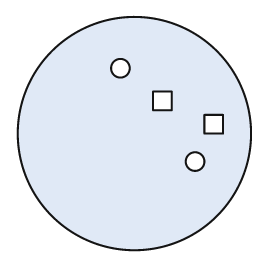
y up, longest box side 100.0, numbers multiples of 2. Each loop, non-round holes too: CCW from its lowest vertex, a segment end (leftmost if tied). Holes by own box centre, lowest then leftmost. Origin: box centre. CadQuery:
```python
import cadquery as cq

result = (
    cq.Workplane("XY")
    .moveTo(0.0, 0.0)
    .circle(50.0)
    .moveTo(26.0, -12.0)
    .circle(4.0)
    .moveTo(30.0, 0.0)
    .lineTo(38.0, 0.0)
    .lineTo(38.0, 8.0)
    .lineTo(30.0, 8.0)
    .close()
    .moveTo(8.0, 10.0)
    .lineTo(16.0, 10.0)
    .lineTo(16.0, 18.0)
    .lineTo(8.0, 18.0)
    .close()
    .moveTo(-6.0, 28.0)
    .circle(4.0)
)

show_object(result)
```